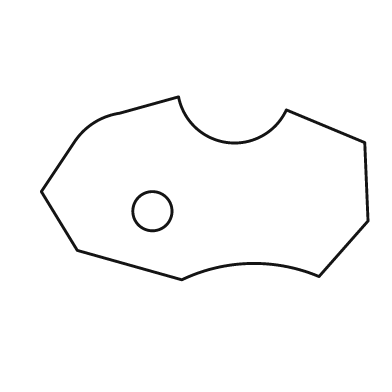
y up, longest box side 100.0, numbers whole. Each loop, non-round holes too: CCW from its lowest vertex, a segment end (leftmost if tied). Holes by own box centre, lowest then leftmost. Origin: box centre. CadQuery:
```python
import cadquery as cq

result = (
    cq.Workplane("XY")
    .moveTo(-7.0, -28.0)
    .threePointArc((14.0, -23.0), (35.0, -27.0))
    .lineTo(50.0, -10.0)
    .lineTo(49.0, 14.0)
    .lineTo(25.0, 24.0)
    .threePointArc((7.0, 14.0), (-8.0, 28.0))
    .lineTo(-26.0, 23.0)
    .threePointArc((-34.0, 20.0), (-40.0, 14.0))
    .lineTo(-50.0, -1.0)
    .lineTo(-39.0, -19.0)
    .close()
    .moveTo(-16.0, -7.0)
    .circle(6.0)
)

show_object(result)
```